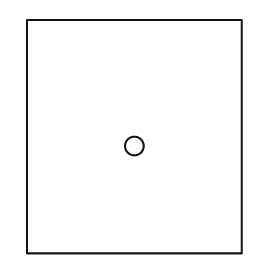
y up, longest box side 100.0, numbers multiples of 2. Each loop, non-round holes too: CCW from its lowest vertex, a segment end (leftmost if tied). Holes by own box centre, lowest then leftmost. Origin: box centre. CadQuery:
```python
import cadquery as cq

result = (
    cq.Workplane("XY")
    .moveTo(-46.0, -50.0)
    .lineTo(46.0, -50.0)
    .lineTo(46.0, 50.0)
    .lineTo(-46.0, 50.0)
    .close()
    .moveTo(0.0, -4.0)
    .circle(4.0)
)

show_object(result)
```